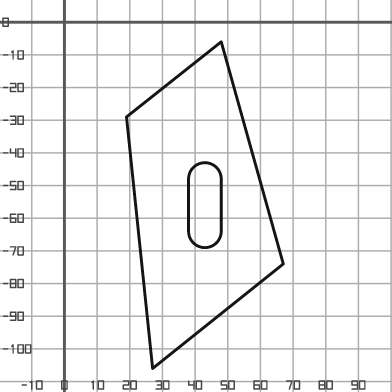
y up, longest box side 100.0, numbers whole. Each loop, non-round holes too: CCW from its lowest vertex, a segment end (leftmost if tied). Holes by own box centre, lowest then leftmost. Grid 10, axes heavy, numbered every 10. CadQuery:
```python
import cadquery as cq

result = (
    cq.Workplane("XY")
    .moveTo(27.0, -106.0)
    .lineTo(67.0, -74.0)
    .lineTo(48.0, -6.0)
    .lineTo(19.0, -29.0)
    .close()
    .moveTo(38.0, -64.0)
    .threePointArc((43.0, -69.0), (48.0, -64.0))
    .lineTo(48.0, -48.0)
    .threePointArc((43.0, -43.0), (38.0, -48.0))
    .close()
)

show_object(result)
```